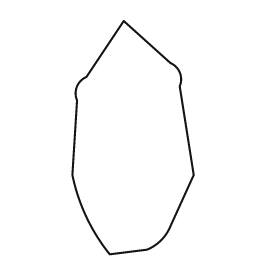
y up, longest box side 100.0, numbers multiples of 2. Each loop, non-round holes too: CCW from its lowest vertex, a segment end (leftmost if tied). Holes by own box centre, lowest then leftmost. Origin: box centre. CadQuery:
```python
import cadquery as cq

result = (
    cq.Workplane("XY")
    .moveTo(-10.0, -50.0)
    .lineTo(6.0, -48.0)
    .threePointArc((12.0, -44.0), (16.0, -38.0))
    .lineTo(26.0, -16.0)
    .lineTo(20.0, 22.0)
    .threePointArc((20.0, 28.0), (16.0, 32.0))
    .lineTo(-4.0, 50.0)
    .lineTo(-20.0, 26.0)
    .threePointArc((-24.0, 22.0), (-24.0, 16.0))
    .lineTo(-26.0, -16.0)
    .threePointArc((-20.0, -34.0), (-10.0, -50.0))
    .close()
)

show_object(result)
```